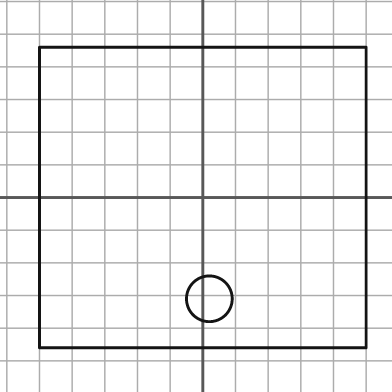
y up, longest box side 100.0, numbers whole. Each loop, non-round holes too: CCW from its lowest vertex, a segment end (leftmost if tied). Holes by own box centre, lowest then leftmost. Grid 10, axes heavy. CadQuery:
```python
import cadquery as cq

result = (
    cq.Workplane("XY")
    .moveTo(-50.0, -46.0)
    .lineTo(50.0, -46.0)
    .lineTo(50.0, 46.0)
    .lineTo(-50.0, 46.0)
    .close()
    .moveTo(2.0, -31.0)
    .circle(7.0)
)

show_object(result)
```